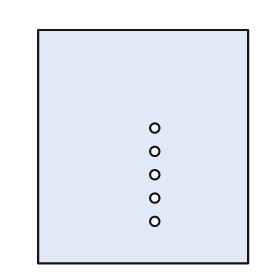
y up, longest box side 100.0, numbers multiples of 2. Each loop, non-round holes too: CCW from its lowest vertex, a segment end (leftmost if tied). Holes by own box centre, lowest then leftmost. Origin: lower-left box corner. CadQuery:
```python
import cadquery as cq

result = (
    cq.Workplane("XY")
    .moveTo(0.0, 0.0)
    .lineTo(90.0, 0.0)
    .lineTo(90.0, 100.0)
    .lineTo(0.0, 100.0)
    .close()
    .moveTo(50.0, 18.0)
    .circle(2.0)
    .moveTo(50.0, 28.0)
    .circle(2.0)
    .moveTo(50.0, 38.0)
    .circle(2.0)
    .moveTo(50.0, 48.0)
    .circle(2.0)
    .moveTo(50.0, 58.0)
    .circle(2.0)
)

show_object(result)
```